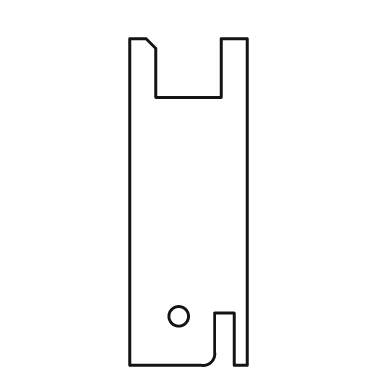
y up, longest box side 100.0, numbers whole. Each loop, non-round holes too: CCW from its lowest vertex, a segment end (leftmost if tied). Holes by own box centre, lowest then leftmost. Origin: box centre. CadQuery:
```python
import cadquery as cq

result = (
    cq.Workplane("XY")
    .moveTo(-18.0, -50.0)
    .lineTo(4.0, -50.0)
    .threePointArc((7.0, -49.0), (8.0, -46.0))
    .lineTo(8.0, -34.0)
    .lineTo(14.0, -34.0)
    .lineTo(14.0, -50.0)
    .lineTo(18.0, -50.0)
    .lineTo(18.0, 50.0)
    .lineTo(10.0, 50.0)
    .lineTo(10.0, 32.0)
    .lineTo(-10.0, 32.0)
    .lineTo(-10.0, 47.0)
    .lineTo(-13.0, 50.0)
    .lineTo(-18.0, 50.0)
    .close()
    .moveTo(-3.0, -35.0)
    .circle(3.0)
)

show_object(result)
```